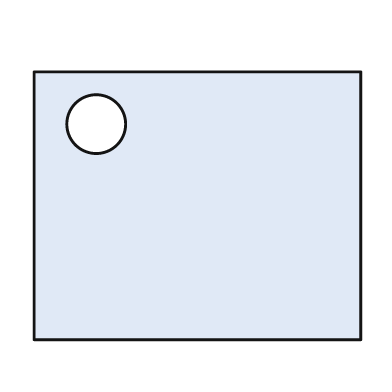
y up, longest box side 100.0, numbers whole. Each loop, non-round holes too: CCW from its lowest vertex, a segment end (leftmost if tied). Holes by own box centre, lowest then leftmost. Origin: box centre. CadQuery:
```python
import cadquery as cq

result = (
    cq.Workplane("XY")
    .moveTo(-50.0, -41.0)
    .lineTo(50.0, -41.0)
    .lineTo(50.0, 41.0)
    .lineTo(-50.0, 41.0)
    .close()
    .moveTo(-31.0, 25.0)
    .circle(9.0)
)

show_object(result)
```